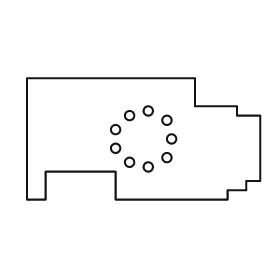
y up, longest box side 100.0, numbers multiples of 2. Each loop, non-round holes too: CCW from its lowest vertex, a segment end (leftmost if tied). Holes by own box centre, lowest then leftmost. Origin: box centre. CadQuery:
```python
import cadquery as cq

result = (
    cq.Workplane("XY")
    .moveTo(-50.0, -26.0)
    .lineTo(-42.0, -26.0)
    .lineTo(-42.0, -14.0)
    .lineTo(-12.0, -14.0)
    .lineTo(-12.0, -26.0)
    .lineTo(36.0, -26.0)
    .lineTo(36.0, -22.0)
    .lineTo(44.0, -22.0)
    .lineTo(44.0, -18.0)
    .lineTo(50.0, -18.0)
    .lineTo(50.0, 10.0)
    .lineTo(40.0, 10.0)
    .lineTo(40.0, 14.0)
    .lineTo(22.0, 14.0)
    .lineTo(22.0, 26.0)
    .lineTo(-50.0, 26.0)
    .close()
    .moveTo(2.0, -12.0)
    .circle(2.0)
    .moveTo(-6.0, -10.0)
    .circle(2.0)
    .moveTo(10.0, -8.0)
    .circle(2.0)
    .moveTo(-12.0, -4.0)
    .circle(2.0)
    .moveTo(12.0, 0.0)
    .circle(2.0)
    .moveTo(-12.0, 4.0)
    .circle(2.0)
    .moveTo(10.0, 8.0)
    .circle(2.0)
    .moveTo(-6.0, 10.0)
    .circle(2.0)
    .moveTo(2.0, 12.0)
    .circle(2.0)
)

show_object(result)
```